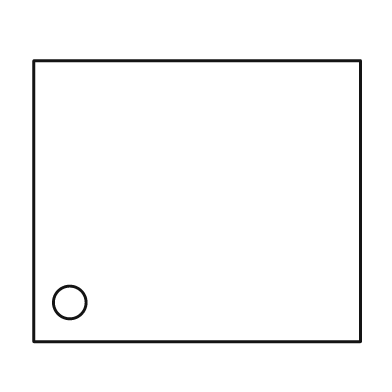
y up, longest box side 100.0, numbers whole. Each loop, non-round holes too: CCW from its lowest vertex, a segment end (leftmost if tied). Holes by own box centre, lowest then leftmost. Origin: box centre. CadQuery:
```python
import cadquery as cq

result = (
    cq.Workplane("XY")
    .moveTo(-50.0, -43.0)
    .lineTo(50.0, -43.0)
    .lineTo(50.0, 43.0)
    .lineTo(-50.0, 43.0)
    .close()
    .moveTo(-39.0, -31.0)
    .circle(5.0)
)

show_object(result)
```